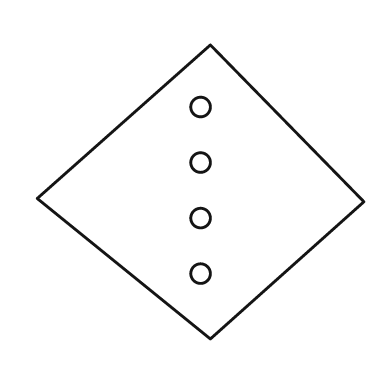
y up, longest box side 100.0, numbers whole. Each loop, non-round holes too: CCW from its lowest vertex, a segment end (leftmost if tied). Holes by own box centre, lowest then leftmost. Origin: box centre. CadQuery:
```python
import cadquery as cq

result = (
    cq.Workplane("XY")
    .moveTo(3.0, -45.0)
    .lineTo(50.0, -3.0)
    .lineTo(3.0, 45.0)
    .lineTo(-50.0, -2.0)
    .close()
    .moveTo(0.0, -25.0)
    .circle(3.0)
    .moveTo(0.0, -8.0)
    .circle(3.0)
    .moveTo(0.0, 9.0)
    .circle(3.0)
    .moveTo(0.0, 26.0)
    .circle(3.0)
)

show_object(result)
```